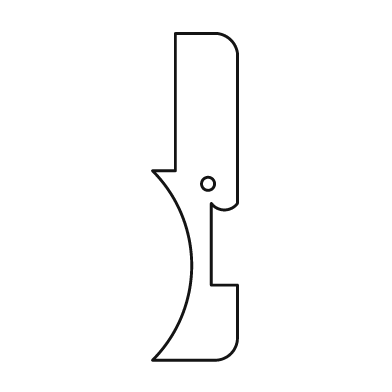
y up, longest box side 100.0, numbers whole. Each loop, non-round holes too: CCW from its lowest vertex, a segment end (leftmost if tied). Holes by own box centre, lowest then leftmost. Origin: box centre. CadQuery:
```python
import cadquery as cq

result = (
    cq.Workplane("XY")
    .moveTo(-13.0, -50.0)
    .lineTo(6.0, -50.0)
    .threePointArc((11.0, -48.0), (13.0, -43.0))
    .lineTo(13.0, -27.0)
    .lineTo(5.0, -27.0)
    .lineTo(5.0, -2.0)
    .threePointArc((9.0, -4.0), (13.0, -2.0))
    .lineTo(13.0, 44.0)
    .threePointArc((11.0, 48.0), (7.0, 50.0))
    .lineTo(-6.0, 50.0)
    .lineTo(-6.0, 8.0)
    .lineTo(-13.0, 8.0)
    .threePointArc((-1.0, -21.0), (-13.0, -50.0))
    .close()
    .moveTo(4.0, 4.0)
    .circle(2.0)
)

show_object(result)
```